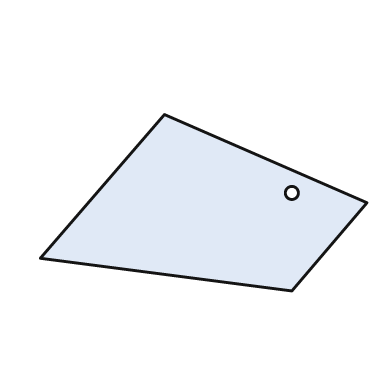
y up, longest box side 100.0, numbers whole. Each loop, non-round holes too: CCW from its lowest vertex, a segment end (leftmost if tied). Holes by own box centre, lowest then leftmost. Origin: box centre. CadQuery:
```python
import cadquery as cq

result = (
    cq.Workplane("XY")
    .moveTo(27.0, -27.0)
    .lineTo(50.0, 0.0)
    .lineTo(-12.0, 27.0)
    .lineTo(-50.0, -17.0)
    .close()
    .moveTo(27.0, 3.0)
    .circle(2.0)
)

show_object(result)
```